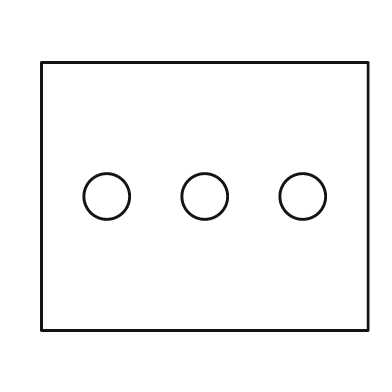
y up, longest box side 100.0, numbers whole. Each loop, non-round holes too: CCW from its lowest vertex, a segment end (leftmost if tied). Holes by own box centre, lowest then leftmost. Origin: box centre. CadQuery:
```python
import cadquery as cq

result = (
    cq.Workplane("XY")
    .moveTo(-50.0, -41.0)
    .lineTo(50.0, -41.0)
    .lineTo(50.0, 41.0)
    .lineTo(-50.0, 41.0)
    .close()
    .moveTo(-30.0, 0.0)
    .circle(7.0)
    .moveTo(0.0, 0.0)
    .circle(7.0)
    .moveTo(30.0, 0.0)
    .circle(7.0)
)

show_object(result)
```